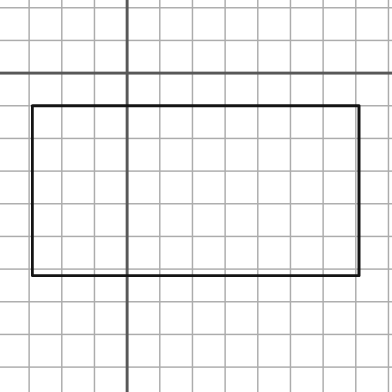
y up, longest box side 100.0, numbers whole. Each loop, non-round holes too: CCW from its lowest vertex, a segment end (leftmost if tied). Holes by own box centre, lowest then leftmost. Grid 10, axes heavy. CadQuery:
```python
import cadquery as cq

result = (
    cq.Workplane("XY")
    .moveTo(-29.0, -62.0)
    .lineTo(71.0, -62.0)
    .lineTo(71.0, -10.0)
    .lineTo(-29.0, -10.0)
    .close()
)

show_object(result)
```